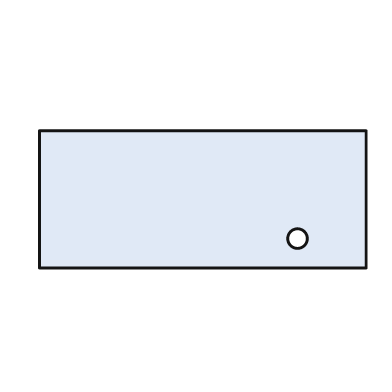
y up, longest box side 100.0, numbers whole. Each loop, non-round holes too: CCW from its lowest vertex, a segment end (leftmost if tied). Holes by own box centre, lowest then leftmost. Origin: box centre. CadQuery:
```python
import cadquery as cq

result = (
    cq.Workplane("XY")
    .moveTo(-50.0, -21.0)
    .lineTo(50.0, -21.0)
    .lineTo(50.0, 21.0)
    .lineTo(-50.0, 21.0)
    .close()
    .moveTo(29.0, -12.0)
    .circle(3.0)
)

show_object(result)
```